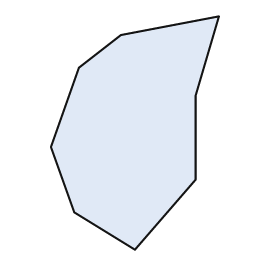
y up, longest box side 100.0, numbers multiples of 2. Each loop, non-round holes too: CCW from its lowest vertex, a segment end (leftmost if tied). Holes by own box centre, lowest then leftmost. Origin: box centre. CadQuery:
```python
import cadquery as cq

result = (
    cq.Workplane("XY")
    .moveTo(0.0, -50.0)
    .lineTo(26.0, -20.0)
    .lineTo(26.0, 16.0)
    .lineTo(36.0, 50.0)
    .lineTo(-6.0, 42.0)
    .lineTo(-24.0, 28.0)
    .lineTo(-36.0, -6.0)
    .lineTo(-26.0, -34.0)
    .close()
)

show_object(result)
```